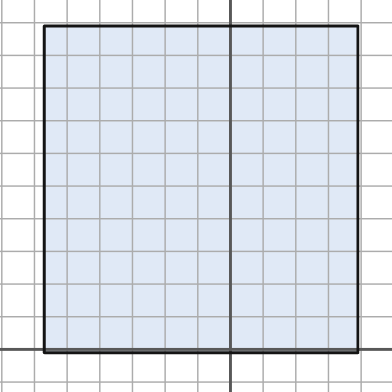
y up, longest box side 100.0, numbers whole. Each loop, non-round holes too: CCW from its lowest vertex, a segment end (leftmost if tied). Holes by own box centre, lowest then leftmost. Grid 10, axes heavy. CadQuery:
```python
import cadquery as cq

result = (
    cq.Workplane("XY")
    .moveTo(-57.0, -1.0)
    .lineTo(39.0, -1.0)
    .lineTo(39.0, 99.0)
    .lineTo(-57.0, 99.0)
    .close()
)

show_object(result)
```